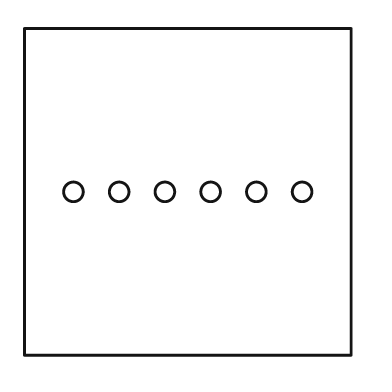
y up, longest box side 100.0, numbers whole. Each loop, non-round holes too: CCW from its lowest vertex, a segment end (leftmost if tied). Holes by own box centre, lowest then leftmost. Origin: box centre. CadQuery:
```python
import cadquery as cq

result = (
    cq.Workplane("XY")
    .moveTo(-50.0, -50.0)
    .lineTo(50.0, -50.0)
    .lineTo(50.0, 50.0)
    .lineTo(-50.0, 50.0)
    .close()
    .moveTo(-35.0, 0.0)
    .circle(3.0)
    .moveTo(-21.0, 0.0)
    .circle(3.0)
    .moveTo(-7.0, 0.0)
    .circle(3.0)
    .moveTo(7.0, 0.0)
    .circle(3.0)
    .moveTo(21.0, 0.0)
    .circle(3.0)
    .moveTo(35.0, 0.0)
    .circle(3.0)
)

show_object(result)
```